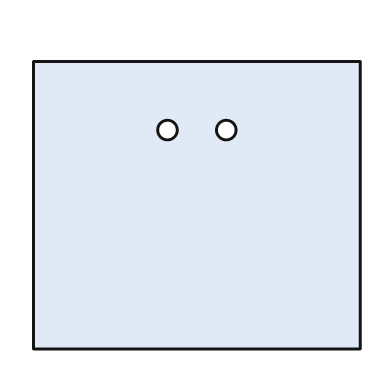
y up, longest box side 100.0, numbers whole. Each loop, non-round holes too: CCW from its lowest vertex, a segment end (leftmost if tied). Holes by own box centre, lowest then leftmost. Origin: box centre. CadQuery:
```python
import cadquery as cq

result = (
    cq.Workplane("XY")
    .moveTo(-50.0, -44.0)
    .lineTo(50.0, -44.0)
    .lineTo(50.0, 44.0)
    .lineTo(-50.0, 44.0)
    .close()
    .moveTo(-9.0, 23.0)
    .circle(3.0)
    .moveTo(9.0, 23.0)
    .circle(3.0)
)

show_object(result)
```